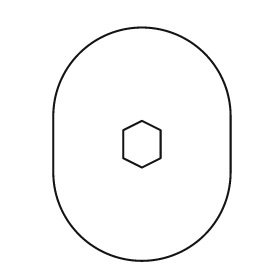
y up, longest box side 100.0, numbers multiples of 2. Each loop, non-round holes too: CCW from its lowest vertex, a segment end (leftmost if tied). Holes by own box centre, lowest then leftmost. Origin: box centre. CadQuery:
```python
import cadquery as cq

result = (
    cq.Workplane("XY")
    .moveTo(-38.0, -12.0)
    .threePointArc((0.0, -50.0), (38.0, -12.0))
    .lineTo(38.0, 12.0)
    .threePointArc((0.0, 50.0), (-38.0, 12.0))
    .close()
    .moveTo(0.0, -10.0)
    .lineTo(8.0, -6.0)
    .lineTo(8.0, 6.0)
    .lineTo(0.0, 10.0)
    .lineTo(-8.0, 6.0)
    .lineTo(-8.0, -6.0)
    .close()
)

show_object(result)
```